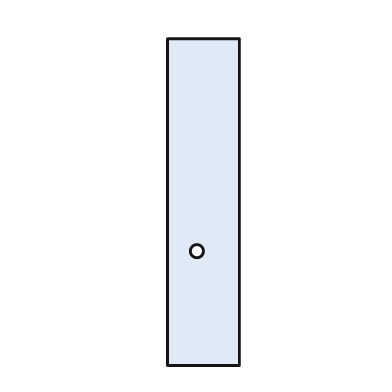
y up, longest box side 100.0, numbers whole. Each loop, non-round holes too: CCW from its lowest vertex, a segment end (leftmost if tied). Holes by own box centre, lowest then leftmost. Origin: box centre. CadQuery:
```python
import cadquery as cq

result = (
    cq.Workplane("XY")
    .moveTo(-11.0, -50.0)
    .lineTo(11.0, -50.0)
    .lineTo(11.0, 50.0)
    .lineTo(-11.0, 50.0)
    .close()
    .moveTo(-2.0, -15.0)
    .circle(2.0)
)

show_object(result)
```